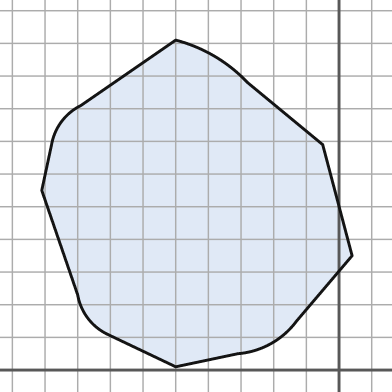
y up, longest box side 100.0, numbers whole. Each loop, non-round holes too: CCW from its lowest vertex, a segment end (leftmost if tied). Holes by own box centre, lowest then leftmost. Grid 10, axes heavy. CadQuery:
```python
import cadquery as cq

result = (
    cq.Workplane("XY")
    .moveTo(-50.0, 1.0)
    .lineTo(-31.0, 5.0)
    .threePointArc((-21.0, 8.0), (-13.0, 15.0))
    .lineTo(4.0, 35.0)
    .lineTo(-5.0, 69.0)
    .lineTo(-28.0, 88.0)
    .threePointArc((-38.0, 96.0), (-50.0, 101.0))
    .lineTo(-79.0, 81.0)
    .threePointArc((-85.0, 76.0), (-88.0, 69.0))
    .lineTo(-91.0, 55.0)
    .lineTo(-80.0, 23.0)
    .threePointArc((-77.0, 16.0), (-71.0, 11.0))
    .close()
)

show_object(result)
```